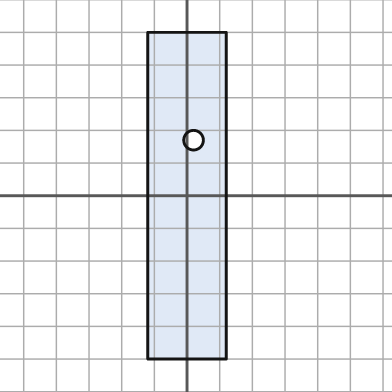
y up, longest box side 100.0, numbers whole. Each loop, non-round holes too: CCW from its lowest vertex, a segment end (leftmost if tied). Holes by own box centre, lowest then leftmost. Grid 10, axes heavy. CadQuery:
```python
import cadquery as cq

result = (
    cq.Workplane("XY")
    .moveTo(-12.0, -50.0)
    .lineTo(12.0, -50.0)
    .lineTo(12.0, 50.0)
    .lineTo(-12.0, 50.0)
    .close()
    .moveTo(2.0, 17.0)
    .circle(3.0)
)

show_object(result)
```